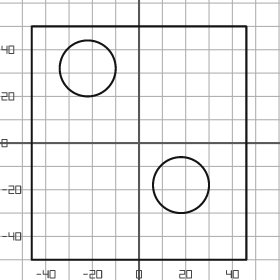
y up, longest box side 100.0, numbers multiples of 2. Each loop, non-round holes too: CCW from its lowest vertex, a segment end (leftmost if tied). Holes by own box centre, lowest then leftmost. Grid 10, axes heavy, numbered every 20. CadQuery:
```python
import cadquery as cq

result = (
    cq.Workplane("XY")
    .moveTo(-46.0, -50.0)
    .lineTo(46.0, -50.0)
    .lineTo(46.0, 50.0)
    .lineTo(-46.0, 50.0)
    .close()
    .moveTo(18.0, -18.0)
    .circle(12.0)
    .moveTo(-22.0, 32.0)
    .circle(12.0)
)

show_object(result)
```